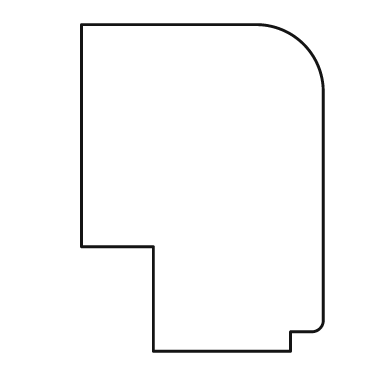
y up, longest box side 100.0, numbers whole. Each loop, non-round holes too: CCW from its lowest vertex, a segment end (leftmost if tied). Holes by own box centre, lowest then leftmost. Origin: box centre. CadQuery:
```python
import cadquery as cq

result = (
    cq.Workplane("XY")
    .moveTo(-15.0, -50.0)
    .lineTo(27.0, -50.0)
    .lineTo(27.0, -44.0)
    .lineTo(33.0, -44.0)
    .threePointArc((36.0, -43.0), (37.0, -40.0))
    .lineTo(37.0, 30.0)
    .threePointArc((31.0, 44.0), (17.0, 50.0))
    .lineTo(-37.0, 50.0)
    .lineTo(-37.0, -18.0)
    .lineTo(-15.0, -18.0)
    .close()
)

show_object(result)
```